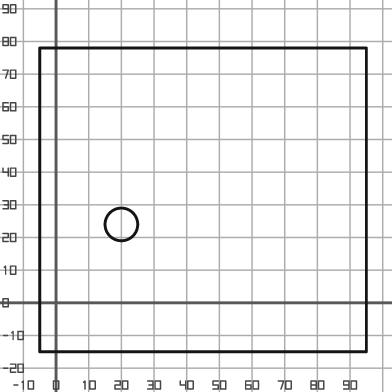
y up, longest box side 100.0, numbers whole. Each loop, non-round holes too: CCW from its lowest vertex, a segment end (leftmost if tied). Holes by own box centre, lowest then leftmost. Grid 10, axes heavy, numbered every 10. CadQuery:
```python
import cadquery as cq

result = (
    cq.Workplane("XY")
    .moveTo(-5.0, -15.0)
    .lineTo(95.0, -15.0)
    .lineTo(95.0, 78.0)
    .lineTo(-5.0, 78.0)
    .close()
    .moveTo(20.0, 24.0)
    .circle(5.0)
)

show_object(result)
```